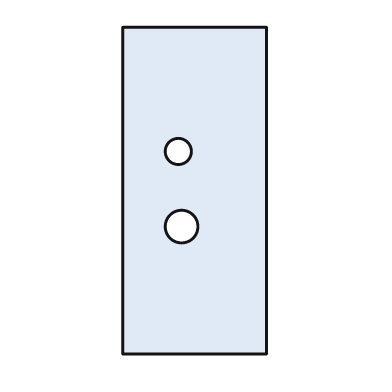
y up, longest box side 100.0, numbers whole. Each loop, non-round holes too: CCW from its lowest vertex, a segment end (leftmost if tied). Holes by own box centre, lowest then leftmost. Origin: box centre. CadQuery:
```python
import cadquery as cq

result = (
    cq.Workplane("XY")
    .moveTo(-22.0, -50.0)
    .lineTo(22.0, -50.0)
    .lineTo(22.0, 50.0)
    .lineTo(-22.0, 50.0)
    .close()
    .moveTo(-4.0, -11.0)
    .circle(5.0)
    .moveTo(-5.0, 12.0)
    .circle(4.0)
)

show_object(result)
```